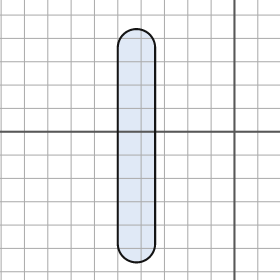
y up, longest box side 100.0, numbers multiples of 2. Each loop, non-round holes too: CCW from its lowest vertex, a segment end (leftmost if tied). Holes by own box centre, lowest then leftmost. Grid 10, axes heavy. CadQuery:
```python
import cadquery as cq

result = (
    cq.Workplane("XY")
    .moveTo(-50.0, -48.0)
    .threePointArc((-42.0, -56.0), (-34.0, -48.0))
    .lineTo(-34.0, 36.0)
    .threePointArc((-42.0, 44.0), (-50.0, 36.0))
    .close()
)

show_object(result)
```